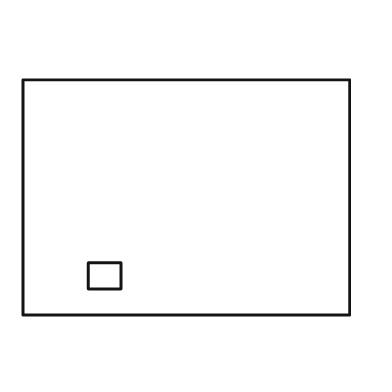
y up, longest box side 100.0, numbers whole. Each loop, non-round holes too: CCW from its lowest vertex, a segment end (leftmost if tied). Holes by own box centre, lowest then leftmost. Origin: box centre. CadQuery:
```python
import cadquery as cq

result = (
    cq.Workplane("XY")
    .moveTo(-50.0, -36.0)
    .lineTo(50.0, -36.0)
    .lineTo(50.0, 36.0)
    .lineTo(-50.0, 36.0)
    .close()
    .moveTo(-30.0, -28.0)
    .lineTo(-20.0, -28.0)
    .lineTo(-20.0, -20.0)
    .lineTo(-30.0, -20.0)
    .close()
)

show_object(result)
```